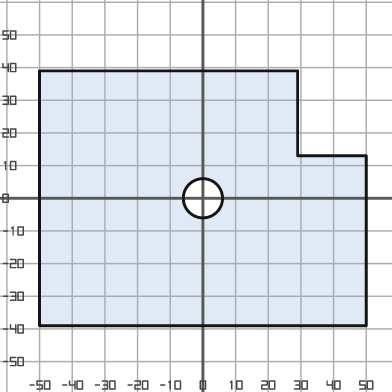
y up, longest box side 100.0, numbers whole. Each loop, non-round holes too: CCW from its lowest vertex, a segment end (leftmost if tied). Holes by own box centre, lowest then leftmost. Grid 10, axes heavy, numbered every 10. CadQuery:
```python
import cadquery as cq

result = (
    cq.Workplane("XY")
    .moveTo(-50.0, -39.0)
    .lineTo(50.0, -39.0)
    .lineTo(50.0, 13.0)
    .lineTo(29.0, 13.0)
    .lineTo(29.0, 39.0)
    .lineTo(-50.0, 39.0)
    .close()
    .moveTo(0.0, 0.0)
    .circle(6.0)
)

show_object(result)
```